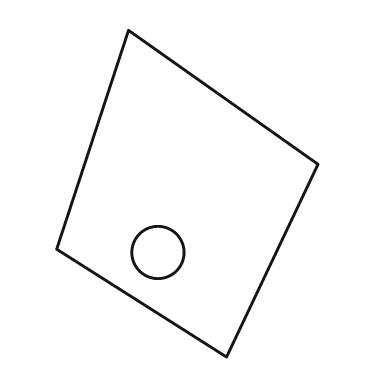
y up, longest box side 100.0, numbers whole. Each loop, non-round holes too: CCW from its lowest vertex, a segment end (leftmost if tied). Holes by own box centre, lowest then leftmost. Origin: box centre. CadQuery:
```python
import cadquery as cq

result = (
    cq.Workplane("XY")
    .moveTo(12.0, -50.0)
    .lineTo(40.0, 9.0)
    .lineTo(-18.0, 50.0)
    .lineTo(-40.0, -17.0)
    .close()
    .moveTo(-9.0, -18.0)
    .circle(8.0)
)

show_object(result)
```